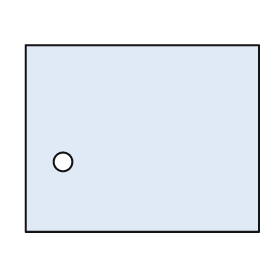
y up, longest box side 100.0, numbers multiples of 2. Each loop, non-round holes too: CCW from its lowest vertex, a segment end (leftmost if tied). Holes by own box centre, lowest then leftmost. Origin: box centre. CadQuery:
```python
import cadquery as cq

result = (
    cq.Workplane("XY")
    .moveTo(-50.0, -40.0)
    .lineTo(50.0, -40.0)
    .lineTo(50.0, 40.0)
    .lineTo(-50.0, 40.0)
    .close()
    .moveTo(-34.0, -10.0)
    .circle(4.0)
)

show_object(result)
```